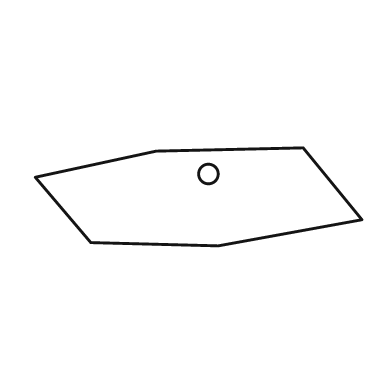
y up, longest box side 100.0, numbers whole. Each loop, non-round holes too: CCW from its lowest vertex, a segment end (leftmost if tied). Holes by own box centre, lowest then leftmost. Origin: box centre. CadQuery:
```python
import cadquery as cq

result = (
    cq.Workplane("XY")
    .moveTo(6.0, -15.0)
    .lineTo(50.0, -7.0)
    .lineTo(32.0, 15.0)
    .lineTo(-13.0, 14.0)
    .lineTo(-50.0, 6.0)
    .lineTo(-33.0, -14.0)
    .close()
    .moveTo(3.0, 7.0)
    .circle(3.0)
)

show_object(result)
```